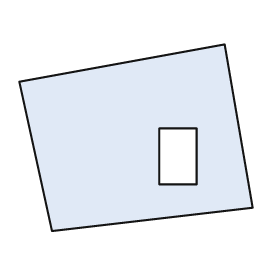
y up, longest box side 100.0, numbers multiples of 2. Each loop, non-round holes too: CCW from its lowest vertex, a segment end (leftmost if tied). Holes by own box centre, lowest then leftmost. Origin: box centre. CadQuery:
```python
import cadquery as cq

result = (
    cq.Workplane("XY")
    .moveTo(-36.0, -40.0)
    .lineTo(50.0, -30.0)
    .lineTo(38.0, 40.0)
    .lineTo(-50.0, 24.0)
    .close()
    .moveTo(10.0, -20.0)
    .lineTo(26.0, -20.0)
    .lineTo(26.0, 4.0)
    .lineTo(10.0, 4.0)
    .close()
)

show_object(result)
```